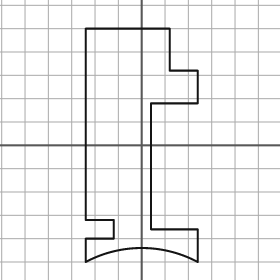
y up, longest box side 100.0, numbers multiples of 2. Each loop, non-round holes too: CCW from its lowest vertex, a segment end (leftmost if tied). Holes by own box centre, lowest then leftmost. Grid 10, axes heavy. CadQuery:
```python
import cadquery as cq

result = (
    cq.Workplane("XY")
    .moveTo(-24.0, -50.0)
    .threePointArc((0.0, -44.0), (24.0, -50.0))
    .lineTo(24.0, -36.0)
    .lineTo(4.0, -36.0)
    .lineTo(4.0, 18.0)
    .lineTo(24.0, 18.0)
    .lineTo(24.0, 32.0)
    .lineTo(12.0, 32.0)
    .lineTo(12.0, 50.0)
    .lineTo(-24.0, 50.0)
    .lineTo(-24.0, -32.0)
    .lineTo(-12.0, -32.0)
    .lineTo(-12.0, -40.0)
    .lineTo(-24.0, -40.0)
    .close()
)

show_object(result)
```